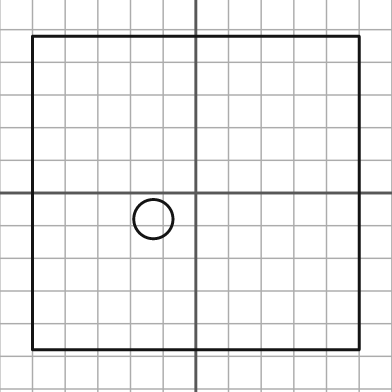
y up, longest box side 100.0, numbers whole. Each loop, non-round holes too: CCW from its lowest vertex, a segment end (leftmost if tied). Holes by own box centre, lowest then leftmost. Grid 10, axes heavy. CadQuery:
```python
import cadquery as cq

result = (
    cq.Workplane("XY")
    .moveTo(-50.0, -48.0)
    .lineTo(50.0, -48.0)
    .lineTo(50.0, 48.0)
    .lineTo(-50.0, 48.0)
    .close()
    .moveTo(-13.0, -8.0)
    .circle(6.0)
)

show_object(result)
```